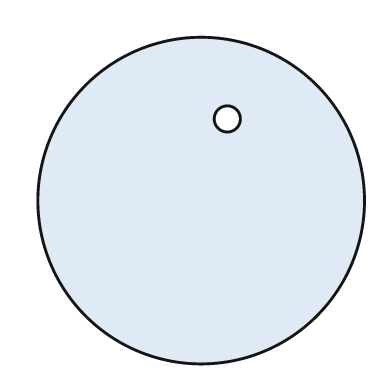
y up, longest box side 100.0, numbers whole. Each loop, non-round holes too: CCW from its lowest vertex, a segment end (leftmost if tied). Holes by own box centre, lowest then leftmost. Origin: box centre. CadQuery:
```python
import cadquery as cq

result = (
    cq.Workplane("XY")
    .moveTo(0.0, 0.0)
    .circle(50.0)
    .moveTo(8.0, 25.0)
    .circle(4.0)
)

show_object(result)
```